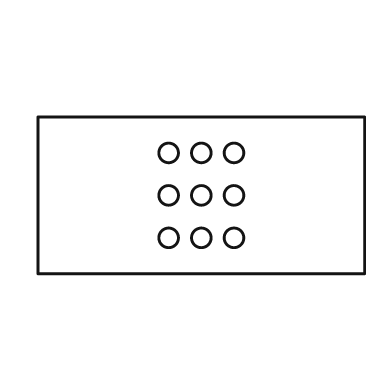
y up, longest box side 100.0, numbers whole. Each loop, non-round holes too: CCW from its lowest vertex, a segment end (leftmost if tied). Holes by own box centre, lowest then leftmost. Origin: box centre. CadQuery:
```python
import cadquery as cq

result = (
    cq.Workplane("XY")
    .moveTo(-50.0, -24.0)
    .lineTo(50.0, -24.0)
    .lineTo(50.0, 24.0)
    .lineTo(-50.0, 24.0)
    .close()
    .moveTo(-10.0, -13.0)
    .circle(3.0)
    .moveTo(0.0, -13.0)
    .circle(3.0)
    .moveTo(10.0, -13.0)
    .circle(3.0)
    .moveTo(-10.0, 0.0)
    .circle(3.0)
    .moveTo(0.0, 0.0)
    .circle(3.0)
    .moveTo(10.0, 0.0)
    .circle(3.0)
    .moveTo(-10.0, 13.0)
    .circle(3.0)
    .moveTo(0.0, 13.0)
    .circle(3.0)
    .moveTo(10.0, 13.0)
    .circle(3.0)
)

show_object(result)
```